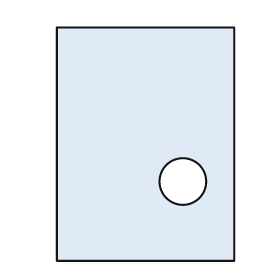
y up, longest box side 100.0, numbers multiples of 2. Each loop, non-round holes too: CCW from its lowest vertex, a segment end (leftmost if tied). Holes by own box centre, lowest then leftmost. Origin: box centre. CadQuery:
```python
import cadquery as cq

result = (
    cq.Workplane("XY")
    .moveTo(-38.0, -50.0)
    .lineTo(38.0, -50.0)
    .lineTo(38.0, 50.0)
    .lineTo(-38.0, 50.0)
    .close()
    .moveTo(16.0, -16.0)
    .circle(10.0)
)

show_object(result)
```